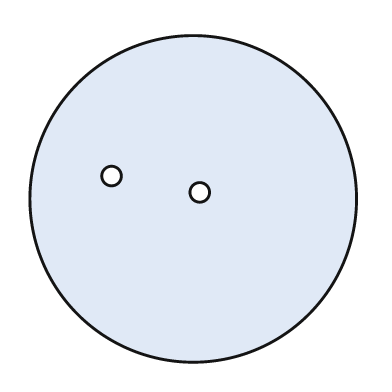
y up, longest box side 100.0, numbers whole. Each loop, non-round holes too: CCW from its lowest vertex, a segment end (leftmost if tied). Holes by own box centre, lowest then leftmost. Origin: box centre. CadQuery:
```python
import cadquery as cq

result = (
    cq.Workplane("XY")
    .moveTo(0.0, 0.0)
    .circle(50.0)
    .moveTo(2.0, 2.0)
    .circle(3.0)
    .moveTo(-25.0, 7.0)
    .circle(3.0)
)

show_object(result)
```